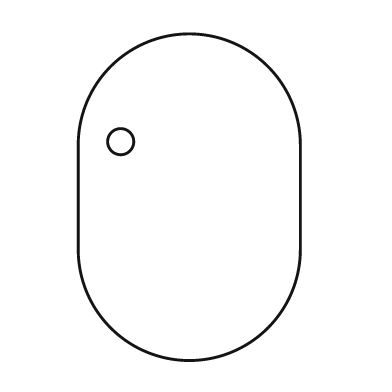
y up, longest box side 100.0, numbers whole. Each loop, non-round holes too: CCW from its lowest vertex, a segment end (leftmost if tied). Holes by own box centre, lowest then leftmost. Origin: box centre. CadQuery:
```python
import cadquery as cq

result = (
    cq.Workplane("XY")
    .moveTo(-34.0, -16.0)
    .threePointArc((0.0, -50.0), (34.0, -16.0))
    .lineTo(34.0, 16.0)
    .threePointArc((0.0, 50.0), (-34.0, 16.0))
    .close()
    .moveTo(-21.0, 17.0)
    .circle(4.0)
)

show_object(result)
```